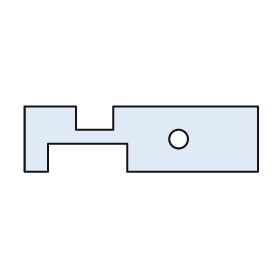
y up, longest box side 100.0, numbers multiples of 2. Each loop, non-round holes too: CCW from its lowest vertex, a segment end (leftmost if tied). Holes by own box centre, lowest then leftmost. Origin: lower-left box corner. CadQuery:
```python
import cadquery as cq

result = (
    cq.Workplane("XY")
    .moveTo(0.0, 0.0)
    .lineTo(10.0, 0.0)
    .lineTo(10.0, 12.0)
    .lineTo(44.0, 12.0)
    .lineTo(44.0, 0.0)
    .lineTo(100.0, 0.0)
    .lineTo(100.0, 28.0)
    .lineTo(38.0, 28.0)
    .lineTo(38.0, 18.0)
    .lineTo(22.0, 18.0)
    .lineTo(22.0, 28.0)
    .lineTo(0.0, 28.0)
    .close()
    .moveTo(66.0, 14.0)
    .circle(4.0)
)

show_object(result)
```